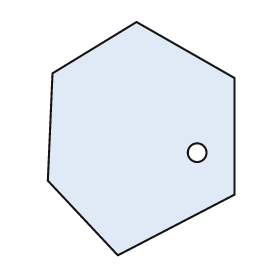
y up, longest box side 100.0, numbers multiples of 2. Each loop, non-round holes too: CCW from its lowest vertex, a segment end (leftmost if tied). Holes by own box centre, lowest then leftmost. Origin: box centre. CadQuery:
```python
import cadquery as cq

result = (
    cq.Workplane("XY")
    .moveTo(-10.0, -50.0)
    .lineTo(40.0, -24.0)
    .lineTo(40.0, 26.0)
    .lineTo(-2.0, 50.0)
    .lineTo(-38.0, 28.0)
    .lineTo(-40.0, -18.0)
    .close()
    .moveTo(24.0, -6.0)
    .circle(4.0)
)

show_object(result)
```